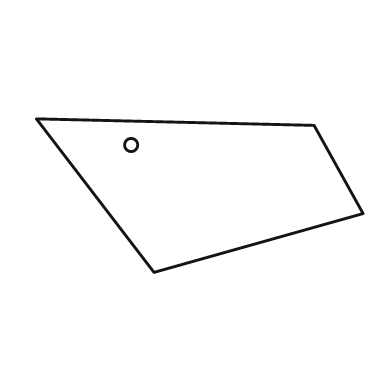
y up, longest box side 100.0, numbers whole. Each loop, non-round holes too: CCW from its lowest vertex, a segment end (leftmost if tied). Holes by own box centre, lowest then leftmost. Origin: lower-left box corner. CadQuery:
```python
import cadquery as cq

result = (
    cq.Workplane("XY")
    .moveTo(36.0, 0.0)
    .lineTo(100.0, 18.0)
    .lineTo(85.0, 45.0)
    .lineTo(0.0, 47.0)
    .close()
    .moveTo(29.0, 39.0)
    .circle(2.0)
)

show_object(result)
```